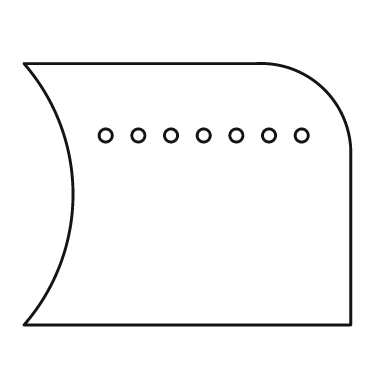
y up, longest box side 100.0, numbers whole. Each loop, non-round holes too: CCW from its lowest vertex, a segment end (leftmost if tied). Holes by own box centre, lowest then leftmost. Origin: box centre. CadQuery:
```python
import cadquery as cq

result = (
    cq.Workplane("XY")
    .moveTo(-50.0, -40.0)
    .lineTo(50.0, -40.0)
    .lineTo(50.0, 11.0)
    .threePointArc((42.0, 32.0), (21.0, 40.0))
    .lineTo(-50.0, 40.0)
    .threePointArc((-35.0, 0.0), (-50.0, -40.0))
    .close()
    .moveTo(-25.0, 18.0)
    .circle(2.0)
    .moveTo(-15.0, 18.0)
    .circle(2.0)
    .moveTo(-5.0, 18.0)
    .circle(2.0)
    .moveTo(5.0, 18.0)
    .circle(2.0)
    .moveTo(15.0, 18.0)
    .circle(2.0)
    .moveTo(25.0, 18.0)
    .circle(2.0)
    .moveTo(35.0, 18.0)
    .circle(2.0)
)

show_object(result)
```